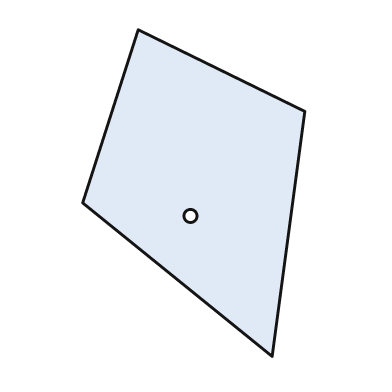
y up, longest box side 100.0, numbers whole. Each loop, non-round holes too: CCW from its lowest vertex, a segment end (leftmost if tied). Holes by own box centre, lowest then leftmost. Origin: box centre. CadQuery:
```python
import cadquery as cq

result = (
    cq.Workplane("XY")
    .moveTo(24.0, -50.0)
    .lineTo(34.0, 25.0)
    .lineTo(-17.0, 50.0)
    .lineTo(-34.0, -3.0)
    .close()
    .moveTo(-1.0, -7.0)
    .circle(2.0)
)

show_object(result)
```